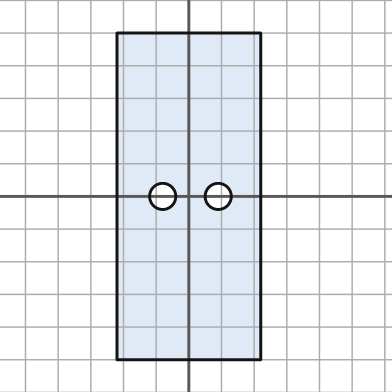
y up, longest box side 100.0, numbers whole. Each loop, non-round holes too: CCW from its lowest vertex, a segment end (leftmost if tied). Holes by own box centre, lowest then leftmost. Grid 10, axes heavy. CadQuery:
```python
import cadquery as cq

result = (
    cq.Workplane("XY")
    .moveTo(-22.0, -50.0)
    .lineTo(22.0, -50.0)
    .lineTo(22.0, 50.0)
    .lineTo(-22.0, 50.0)
    .close()
    .moveTo(-8.0, 0.0)
    .circle(4.0)
    .moveTo(9.0, 0.0)
    .circle(4.0)
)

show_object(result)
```